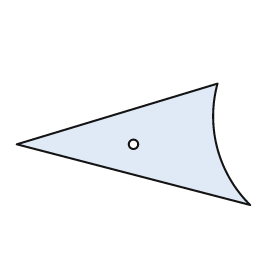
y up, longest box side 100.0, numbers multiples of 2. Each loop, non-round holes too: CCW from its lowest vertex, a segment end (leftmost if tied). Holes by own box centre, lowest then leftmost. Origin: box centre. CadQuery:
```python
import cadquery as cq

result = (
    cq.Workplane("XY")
    .moveTo(50.0, -26.0)
    .threePointArc((36.0, -2.0), (36.0, 26.0))
    .lineTo(-50.0, 0.0)
    .close()
    .moveTo(0.0, 0.0)
    .circle(2.0)
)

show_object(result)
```